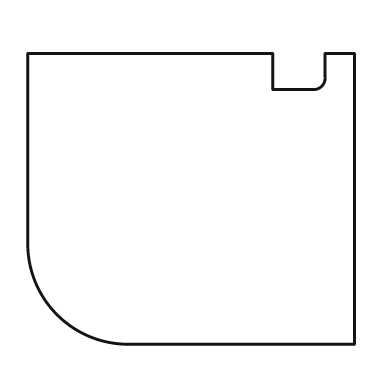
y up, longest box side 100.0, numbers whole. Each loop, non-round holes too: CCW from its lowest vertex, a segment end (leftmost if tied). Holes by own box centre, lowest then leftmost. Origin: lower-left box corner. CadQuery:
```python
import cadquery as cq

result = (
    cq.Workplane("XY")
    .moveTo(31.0, 0.0)
    .lineTo(100.0, 0.0)
    .lineTo(100.0, 89.0)
    .lineTo(91.0, 89.0)
    .lineTo(91.0, 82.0)
    .threePointArc((90.0, 79.0), (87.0, 78.0))
    .lineTo(75.0, 78.0)
    .lineTo(75.0, 89.0)
    .lineTo(0.0, 89.0)
    .lineTo(0.0, 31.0)
    .threePointArc((9.0, 9.0), (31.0, 0.0))
    .close()
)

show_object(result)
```